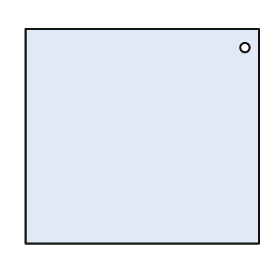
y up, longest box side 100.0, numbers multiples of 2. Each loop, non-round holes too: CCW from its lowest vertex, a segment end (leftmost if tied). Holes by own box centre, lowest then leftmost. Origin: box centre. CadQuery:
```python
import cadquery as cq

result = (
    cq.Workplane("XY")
    .moveTo(-50.0, -46.0)
    .lineTo(50.0, -46.0)
    .lineTo(50.0, 46.0)
    .lineTo(-50.0, 46.0)
    .close()
    .moveTo(44.0, 38.0)
    .circle(2.0)
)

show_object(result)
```